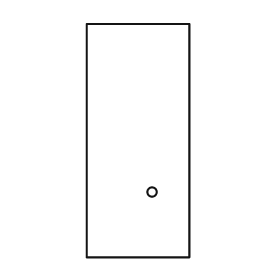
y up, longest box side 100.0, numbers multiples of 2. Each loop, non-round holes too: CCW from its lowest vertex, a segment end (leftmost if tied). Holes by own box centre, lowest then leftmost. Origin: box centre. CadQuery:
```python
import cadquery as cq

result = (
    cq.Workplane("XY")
    .moveTo(-22.0, -50.0)
    .lineTo(22.0, -50.0)
    .lineTo(22.0, 50.0)
    .lineTo(-22.0, 50.0)
    .close()
    .moveTo(6.0, -22.0)
    .circle(2.0)
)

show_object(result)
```